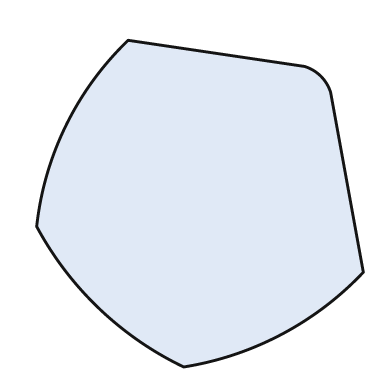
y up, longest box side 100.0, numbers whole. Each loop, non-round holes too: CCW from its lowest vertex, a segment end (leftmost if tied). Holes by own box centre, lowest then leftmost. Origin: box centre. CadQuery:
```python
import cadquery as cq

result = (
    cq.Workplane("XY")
    .moveTo(-5.0, -50.0)
    .threePointArc((25.0, -40.0), (50.0, -21.0))
    .lineTo(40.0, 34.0)
    .threePointArc((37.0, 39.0), (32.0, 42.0))
    .lineTo(-22.0, 50.0)
    .threePointArc((-41.0, 24.0), (-50.0, -7.0))
    .threePointArc((-31.0, -32.0), (-5.0, -50.0))
    .close()
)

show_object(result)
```